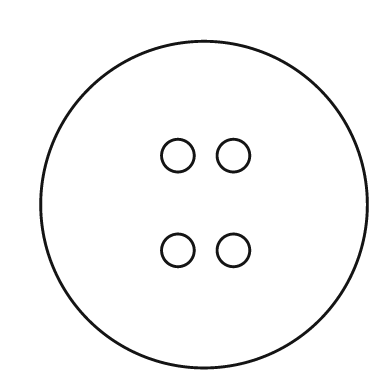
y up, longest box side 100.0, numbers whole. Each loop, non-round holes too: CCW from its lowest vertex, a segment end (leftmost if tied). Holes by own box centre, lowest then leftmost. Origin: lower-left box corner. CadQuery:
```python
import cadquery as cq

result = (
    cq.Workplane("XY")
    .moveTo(50.0, 50.0)
    .circle(50.0)
    .moveTo(42.0, 36.0)
    .circle(5.0)
    .moveTo(59.0, 36.0)
    .circle(5.0)
    .moveTo(42.0, 65.0)
    .circle(5.0)
    .moveTo(59.0, 65.0)
    .circle(5.0)
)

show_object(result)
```